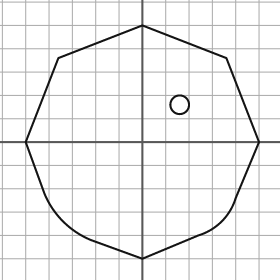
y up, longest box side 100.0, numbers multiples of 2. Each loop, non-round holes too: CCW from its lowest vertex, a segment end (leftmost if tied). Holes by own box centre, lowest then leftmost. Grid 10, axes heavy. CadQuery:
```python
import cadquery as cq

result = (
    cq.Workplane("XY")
    .moveTo(0.0, -50.0)
    .lineTo(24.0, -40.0)
    .threePointArc((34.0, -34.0), (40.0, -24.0))
    .lineTo(50.0, 0.0)
    .lineTo(36.0, 36.0)
    .lineTo(0.0, 50.0)
    .lineTo(-36.0, 36.0)
    .lineTo(-50.0, 0.0)
    .lineTo(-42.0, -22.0)
    .threePointArc((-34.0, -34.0), (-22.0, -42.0))
    .close()
    .moveTo(16.0, 16.0)
    .circle(4.0)
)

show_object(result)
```